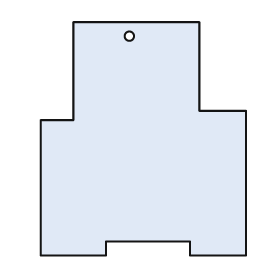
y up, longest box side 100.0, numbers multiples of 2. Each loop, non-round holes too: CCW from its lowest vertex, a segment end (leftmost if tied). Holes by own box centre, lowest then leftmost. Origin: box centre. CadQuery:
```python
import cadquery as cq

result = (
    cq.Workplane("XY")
    .moveTo(-44.0, -50.0)
    .lineTo(-16.0, -50.0)
    .lineTo(-16.0, -44.0)
    .lineTo(20.0, -44.0)
    .lineTo(20.0, -50.0)
    .lineTo(44.0, -50.0)
    .lineTo(44.0, 12.0)
    .lineTo(24.0, 12.0)
    .lineTo(24.0, 50.0)
    .lineTo(-30.0, 50.0)
    .lineTo(-30.0, 8.0)
    .lineTo(-44.0, 8.0)
    .close()
    .moveTo(-6.0, 44.0)
    .circle(2.0)
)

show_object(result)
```